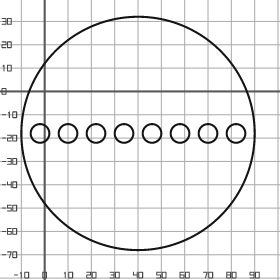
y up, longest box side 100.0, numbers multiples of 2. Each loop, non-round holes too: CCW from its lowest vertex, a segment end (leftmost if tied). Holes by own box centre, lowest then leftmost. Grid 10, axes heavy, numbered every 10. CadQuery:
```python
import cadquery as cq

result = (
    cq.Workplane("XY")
    .moveTo(40.0, -18.0)
    .circle(50.0)
    .moveTo(-2.0, -18.0)
    .circle(4.0)
    .moveTo(10.0, -18.0)
    .circle(4.0)
    .moveTo(22.0, -18.0)
    .circle(4.0)
    .moveTo(34.0, -18.0)
    .circle(4.0)
    .moveTo(46.0, -18.0)
    .circle(4.0)
    .moveTo(58.0, -18.0)
    .circle(4.0)
    .moveTo(70.0, -18.0)
    .circle(4.0)
    .moveTo(82.0, -18.0)
    .circle(4.0)
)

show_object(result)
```